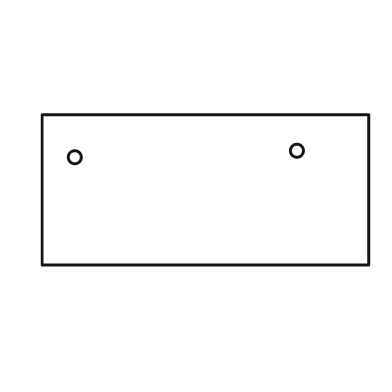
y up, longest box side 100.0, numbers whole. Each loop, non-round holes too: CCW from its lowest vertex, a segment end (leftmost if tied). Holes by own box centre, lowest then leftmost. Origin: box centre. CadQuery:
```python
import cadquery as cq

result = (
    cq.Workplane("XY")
    .moveTo(-50.0, -23.0)
    .lineTo(50.0, -23.0)
    .lineTo(50.0, 23.0)
    .lineTo(-50.0, 23.0)
    .close()
    .moveTo(-40.0, 10.0)
    .circle(2.0)
    .moveTo(28.0, 12.0)
    .circle(2.0)
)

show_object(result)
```